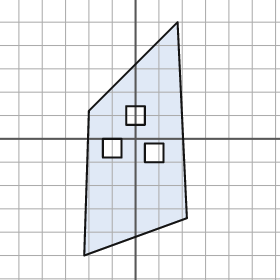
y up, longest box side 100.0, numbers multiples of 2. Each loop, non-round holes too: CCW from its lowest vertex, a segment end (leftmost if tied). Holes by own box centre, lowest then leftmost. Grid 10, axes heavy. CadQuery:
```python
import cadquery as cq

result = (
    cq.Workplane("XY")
    .moveTo(-22.0, -50.0)
    .lineTo(22.0, -34.0)
    .lineTo(18.0, 50.0)
    .lineTo(-20.0, 12.0)
    .close()
    .moveTo(4.0, -10.0)
    .lineTo(12.0, -10.0)
    .lineTo(12.0, -2.0)
    .lineTo(4.0, -2.0)
    .close()
    .moveTo(-14.0, -8.0)
    .lineTo(-6.0, -8.0)
    .lineTo(-6.0, 0.0)
    .lineTo(-14.0, 0.0)
    .close()
    .moveTo(-4.0, 6.0)
    .lineTo(4.0, 6.0)
    .lineTo(4.0, 14.0)
    .lineTo(-4.0, 14.0)
    .close()
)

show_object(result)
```